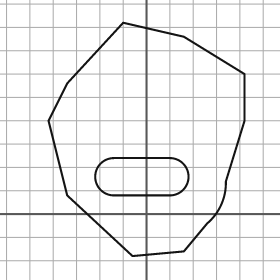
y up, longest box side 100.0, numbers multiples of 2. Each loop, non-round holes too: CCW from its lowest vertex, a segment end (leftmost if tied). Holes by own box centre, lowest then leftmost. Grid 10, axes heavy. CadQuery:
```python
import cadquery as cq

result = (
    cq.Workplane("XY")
    .moveTo(-6.0, -18.0)
    .lineTo(16.0, -16.0)
    .lineTo(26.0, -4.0)
    .threePointArc((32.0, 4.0), (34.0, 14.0))
    .lineTo(42.0, 40.0)
    .lineTo(42.0, 60.0)
    .lineTo(16.0, 76.0)
    .lineTo(-10.0, 82.0)
    .lineTo(-34.0, 56.0)
    .lineTo(-42.0, 40.0)
    .lineTo(-34.0, 8.0)
    .close()
    .moveTo(-14.0, 8.0)
    .lineTo(10.0, 8.0)
    .threePointArc((18.0, 16.0), (10.0, 24.0))
    .lineTo(-14.0, 24.0)
    .threePointArc((-22.0, 16.0), (-14.0, 8.0))
    .close()
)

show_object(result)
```